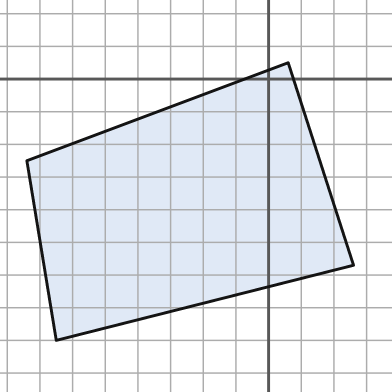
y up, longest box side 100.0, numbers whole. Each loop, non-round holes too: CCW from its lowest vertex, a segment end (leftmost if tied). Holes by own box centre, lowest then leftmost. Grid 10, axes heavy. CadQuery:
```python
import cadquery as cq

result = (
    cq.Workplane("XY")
    .moveTo(-65.0, -80.0)
    .lineTo(26.0, -57.0)
    .lineTo(6.0, 5.0)
    .lineTo(-74.0, -25.0)
    .close()
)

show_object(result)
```